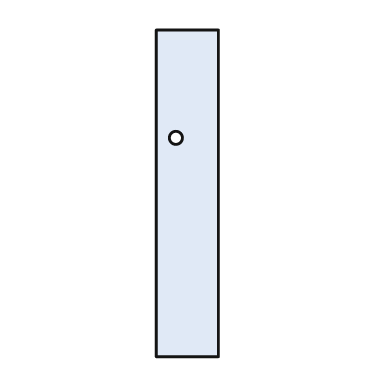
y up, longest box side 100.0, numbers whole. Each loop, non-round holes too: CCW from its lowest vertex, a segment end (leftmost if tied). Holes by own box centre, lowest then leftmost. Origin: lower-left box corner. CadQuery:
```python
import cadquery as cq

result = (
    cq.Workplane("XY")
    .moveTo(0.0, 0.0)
    .lineTo(19.0, 0.0)
    .lineTo(19.0, 100.0)
    .lineTo(0.0, 100.0)
    .close()
    .moveTo(6.0, 67.0)
    .circle(2.0)
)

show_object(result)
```